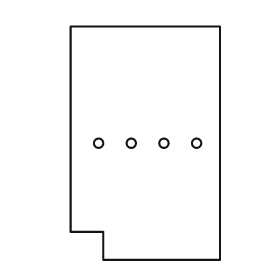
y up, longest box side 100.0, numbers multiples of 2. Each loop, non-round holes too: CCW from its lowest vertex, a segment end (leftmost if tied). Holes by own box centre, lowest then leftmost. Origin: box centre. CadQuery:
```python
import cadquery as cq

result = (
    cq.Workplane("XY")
    .moveTo(-18.0, -50.0)
    .lineTo(32.0, -50.0)
    .lineTo(32.0, 50.0)
    .lineTo(-32.0, 50.0)
    .lineTo(-32.0, -38.0)
    .lineTo(-18.0, -38.0)
    .close()
    .moveTo(-20.0, 0.0)
    .circle(2.0)
    .moveTo(-6.0, 0.0)
    .circle(2.0)
    .moveTo(8.0, 0.0)
    .circle(2.0)
    .moveTo(22.0, 0.0)
    .circle(2.0)
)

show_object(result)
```